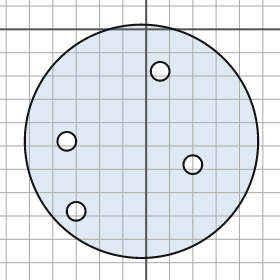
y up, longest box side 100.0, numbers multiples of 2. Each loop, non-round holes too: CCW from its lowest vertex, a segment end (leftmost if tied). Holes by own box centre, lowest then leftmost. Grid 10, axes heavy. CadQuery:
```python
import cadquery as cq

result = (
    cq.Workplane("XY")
    .moveTo(-2.0, -48.0)
    .circle(50.0)
    .moveTo(-30.0, -78.0)
    .circle(4.0)
    .moveTo(20.0, -58.0)
    .circle(4.0)
    .moveTo(-34.0, -48.0)
    .circle(4.0)
    .moveTo(6.0, -18.0)
    .circle(4.0)
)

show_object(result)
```